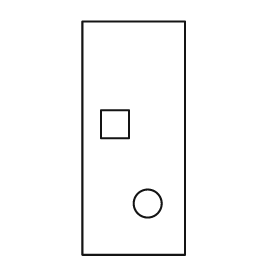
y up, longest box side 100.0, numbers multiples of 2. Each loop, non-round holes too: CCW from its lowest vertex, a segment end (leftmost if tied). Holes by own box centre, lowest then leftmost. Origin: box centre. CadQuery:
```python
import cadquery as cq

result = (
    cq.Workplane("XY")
    .moveTo(-22.0, -50.0)
    .lineTo(22.0, -50.0)
    .lineTo(22.0, 50.0)
    .lineTo(-22.0, 50.0)
    .close()
    .moveTo(6.0, -28.0)
    .circle(6.0)
    .moveTo(-14.0, 0.0)
    .lineTo(-2.0, 0.0)
    .lineTo(-2.0, 12.0)
    .lineTo(-14.0, 12.0)
    .close()
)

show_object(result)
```